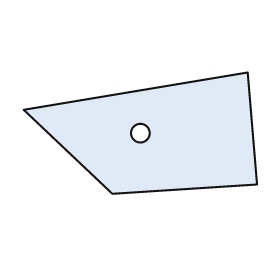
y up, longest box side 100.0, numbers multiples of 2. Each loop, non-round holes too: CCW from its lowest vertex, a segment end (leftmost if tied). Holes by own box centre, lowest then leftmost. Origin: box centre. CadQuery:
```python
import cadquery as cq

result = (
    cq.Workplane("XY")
    .moveTo(-12.0, -26.0)
    .lineTo(50.0, -22.0)
    .lineTo(46.0, 26.0)
    .lineTo(-50.0, 10.0)
    .close()
    .moveTo(0.0, 0.0)
    .circle(4.0)
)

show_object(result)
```